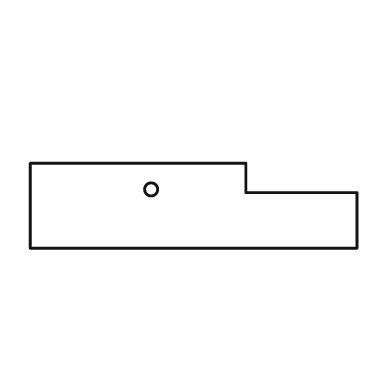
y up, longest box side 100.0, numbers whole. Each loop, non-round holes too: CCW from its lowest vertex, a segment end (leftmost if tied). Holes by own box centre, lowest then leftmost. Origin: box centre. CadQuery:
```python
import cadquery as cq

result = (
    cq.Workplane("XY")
    .moveTo(-50.0, -13.0)
    .lineTo(50.0, -13.0)
    .lineTo(50.0, 4.0)
    .lineTo(16.0, 4.0)
    .lineTo(16.0, 13.0)
    .lineTo(-50.0, 13.0)
    .close()
    .moveTo(-13.0, 5.0)
    .circle(2.0)
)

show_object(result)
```